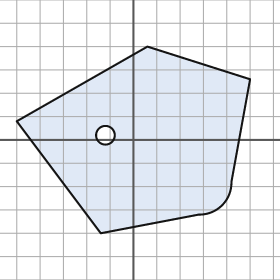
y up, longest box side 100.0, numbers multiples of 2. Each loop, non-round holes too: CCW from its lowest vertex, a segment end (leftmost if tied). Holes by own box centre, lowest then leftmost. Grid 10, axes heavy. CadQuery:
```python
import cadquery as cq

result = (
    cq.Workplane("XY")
    .moveTo(-14.0, -40.0)
    .lineTo(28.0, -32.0)
    .threePointArc((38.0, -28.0), (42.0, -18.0))
    .lineTo(50.0, 26.0)
    .lineTo(6.0, 40.0)
    .lineTo(-50.0, 8.0)
    .close()
    .moveTo(-12.0, 2.0)
    .circle(4.0)
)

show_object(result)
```